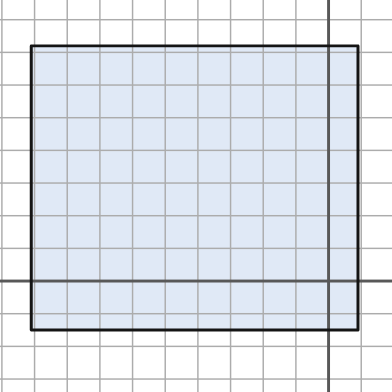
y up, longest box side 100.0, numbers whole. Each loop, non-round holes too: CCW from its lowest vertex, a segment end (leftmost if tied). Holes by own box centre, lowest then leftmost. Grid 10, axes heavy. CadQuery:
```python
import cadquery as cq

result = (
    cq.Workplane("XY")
    .moveTo(-91.0, -15.0)
    .lineTo(9.0, -15.0)
    .lineTo(9.0, 72.0)
    .lineTo(-91.0, 72.0)
    .close()
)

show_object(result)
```